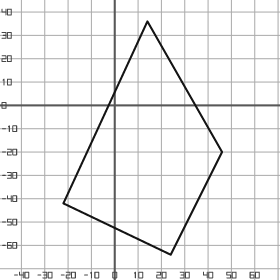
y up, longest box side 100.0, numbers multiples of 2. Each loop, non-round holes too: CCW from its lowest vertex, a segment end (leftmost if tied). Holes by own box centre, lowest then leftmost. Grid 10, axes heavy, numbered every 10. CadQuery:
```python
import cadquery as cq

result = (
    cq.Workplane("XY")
    .moveTo(24.0, -64.0)
    .lineTo(46.0, -20.0)
    .lineTo(14.0, 36.0)
    .lineTo(-22.0, -42.0)
    .close()
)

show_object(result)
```